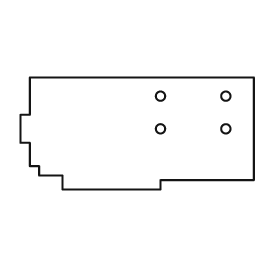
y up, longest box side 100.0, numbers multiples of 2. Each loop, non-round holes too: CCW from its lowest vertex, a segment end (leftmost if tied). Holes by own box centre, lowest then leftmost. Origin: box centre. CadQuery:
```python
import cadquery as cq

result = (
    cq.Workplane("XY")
    .moveTo(-32.0, -24.0)
    .lineTo(10.0, -24.0)
    .lineTo(10.0, -20.0)
    .lineTo(50.0, -20.0)
    .lineTo(50.0, 24.0)
    .lineTo(-46.0, 24.0)
    .lineTo(-46.0, 8.0)
    .lineTo(-50.0, 8.0)
    .lineTo(-50.0, -4.0)
    .lineTo(-46.0, -4.0)
    .lineTo(-46.0, -14.0)
    .lineTo(-42.0, -14.0)
    .lineTo(-42.0, -18.0)
    .lineTo(-32.0, -18.0)
    .close()
    .moveTo(10.0, 2.0)
    .circle(2.0)
    .moveTo(38.0, 2.0)
    .circle(2.0)
    .moveTo(10.0, 16.0)
    .circle(2.0)
    .moveTo(38.0, 16.0)
    .circle(2.0)
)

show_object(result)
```